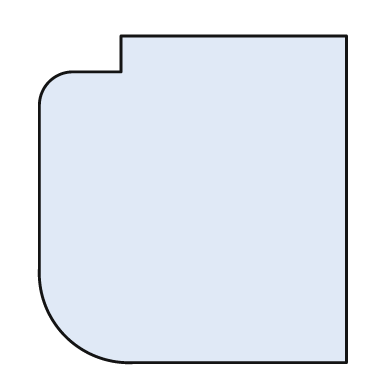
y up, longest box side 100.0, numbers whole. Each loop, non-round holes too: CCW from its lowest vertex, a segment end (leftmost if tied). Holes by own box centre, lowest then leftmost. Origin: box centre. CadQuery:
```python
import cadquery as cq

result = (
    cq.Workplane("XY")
    .moveTo(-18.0, -50.0)
    .lineTo(47.0, -50.0)
    .lineTo(47.0, 50.0)
    .lineTo(-22.0, 50.0)
    .lineTo(-22.0, 39.0)
    .lineTo(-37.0, 39.0)
    .threePointArc((-44.0, 36.0), (-47.0, 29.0))
    .lineTo(-47.0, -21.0)
    .threePointArc((-39.0, -42.0), (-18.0, -50.0))
    .close()
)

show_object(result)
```